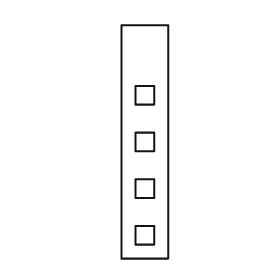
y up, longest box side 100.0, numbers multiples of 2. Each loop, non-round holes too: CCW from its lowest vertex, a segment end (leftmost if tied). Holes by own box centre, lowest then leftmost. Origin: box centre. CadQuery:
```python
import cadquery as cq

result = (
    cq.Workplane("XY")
    .moveTo(-10.0, -50.0)
    .lineTo(10.0, -50.0)
    .lineTo(10.0, 50.0)
    .lineTo(-10.0, 50.0)
    .close()
    .moveTo(-4.0, -44.0)
    .lineTo(4.0, -44.0)
    .lineTo(4.0, -36.0)
    .lineTo(-4.0, -36.0)
    .close()
    .moveTo(-4.0, -24.0)
    .lineTo(4.0, -24.0)
    .lineTo(4.0, -16.0)
    .lineTo(-4.0, -16.0)
    .close()
    .moveTo(-4.0, -4.0)
    .lineTo(4.0, -4.0)
    .lineTo(4.0, 4.0)
    .lineTo(-4.0, 4.0)
    .close()
    .moveTo(-4.0, 16.0)
    .lineTo(4.0, 16.0)
    .lineTo(4.0, 24.0)
    .lineTo(-4.0, 24.0)
    .close()
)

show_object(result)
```